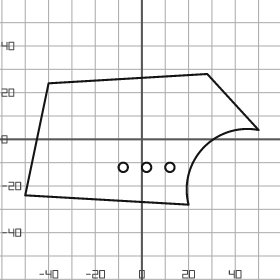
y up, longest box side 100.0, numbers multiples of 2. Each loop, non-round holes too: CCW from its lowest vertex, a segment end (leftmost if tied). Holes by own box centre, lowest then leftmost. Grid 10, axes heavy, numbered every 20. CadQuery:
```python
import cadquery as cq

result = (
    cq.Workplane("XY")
    .moveTo(20.0, -28.0)
    .threePointArc((26.0, -4.0), (50.0, 4.0))
    .lineTo(28.0, 28.0)
    .lineTo(-40.0, 24.0)
    .lineTo(-50.0, -24.0)
    .close()
    .moveTo(-8.0, -12.0)
    .circle(2.0)
    .moveTo(2.0, -12.0)
    .circle(2.0)
    .moveTo(12.0, -12.0)
    .circle(2.0)
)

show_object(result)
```